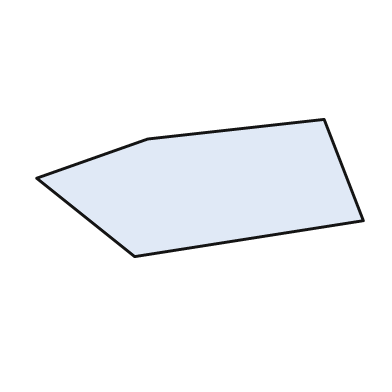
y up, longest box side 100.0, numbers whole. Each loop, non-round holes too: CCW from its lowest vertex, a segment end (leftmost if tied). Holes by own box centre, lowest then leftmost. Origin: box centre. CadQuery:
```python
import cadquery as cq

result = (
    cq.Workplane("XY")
    .moveTo(-20.0, -21.0)
    .lineTo(50.0, -10.0)
    .lineTo(38.0, 21.0)
    .lineTo(-16.0, 15.0)
    .lineTo(-50.0, 3.0)
    .close()
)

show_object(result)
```